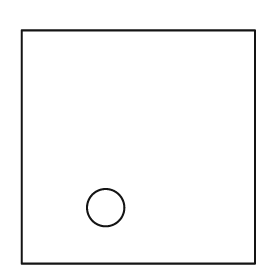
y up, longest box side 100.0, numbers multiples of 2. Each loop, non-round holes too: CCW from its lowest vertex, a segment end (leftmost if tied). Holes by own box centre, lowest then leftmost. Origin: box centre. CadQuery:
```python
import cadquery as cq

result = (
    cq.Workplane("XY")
    .moveTo(-50.0, -50.0)
    .lineTo(50.0, -50.0)
    .lineTo(50.0, 50.0)
    .lineTo(-50.0, 50.0)
    .close()
    .moveTo(-14.0, -26.0)
    .circle(8.0)
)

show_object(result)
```